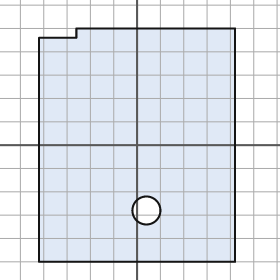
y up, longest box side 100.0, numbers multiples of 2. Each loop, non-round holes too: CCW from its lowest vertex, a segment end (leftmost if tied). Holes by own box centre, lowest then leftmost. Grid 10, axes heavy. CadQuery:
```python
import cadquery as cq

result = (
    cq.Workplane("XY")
    .moveTo(-42.0, -50.0)
    .lineTo(42.0, -50.0)
    .lineTo(42.0, 50.0)
    .lineTo(-26.0, 50.0)
    .lineTo(-26.0, 46.0)
    .lineTo(-42.0, 46.0)
    .close()
    .moveTo(4.0, -28.0)
    .circle(6.0)
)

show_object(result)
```